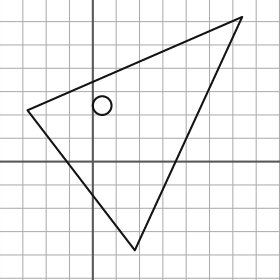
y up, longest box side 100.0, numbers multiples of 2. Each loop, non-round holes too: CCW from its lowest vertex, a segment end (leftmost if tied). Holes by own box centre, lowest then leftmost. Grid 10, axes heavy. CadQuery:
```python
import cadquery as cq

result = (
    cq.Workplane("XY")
    .moveTo(18.0, -38.0)
    .lineTo(64.0, 62.0)
    .lineTo(-28.0, 22.0)
    .close()
    .moveTo(4.0, 24.0)
    .circle(4.0)
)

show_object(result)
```